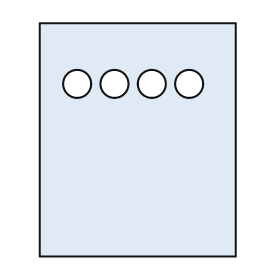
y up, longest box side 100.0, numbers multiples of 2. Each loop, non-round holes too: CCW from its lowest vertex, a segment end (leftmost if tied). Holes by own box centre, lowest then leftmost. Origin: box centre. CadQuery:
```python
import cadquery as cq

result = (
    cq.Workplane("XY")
    .moveTo(-42.0, -50.0)
    .lineTo(42.0, -50.0)
    .lineTo(42.0, 50.0)
    .lineTo(-42.0, 50.0)
    .close()
    .moveTo(-26.0, 24.0)
    .circle(6.0)
    .moveTo(-10.0, 24.0)
    .circle(6.0)
    .moveTo(6.0, 24.0)
    .circle(6.0)
    .moveTo(22.0, 24.0)
    .circle(6.0)
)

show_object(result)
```